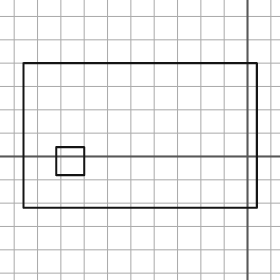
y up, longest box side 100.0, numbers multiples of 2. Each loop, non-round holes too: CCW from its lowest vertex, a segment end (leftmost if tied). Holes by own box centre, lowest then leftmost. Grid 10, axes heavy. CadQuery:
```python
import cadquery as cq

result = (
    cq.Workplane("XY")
    .moveTo(-96.0, -22.0)
    .lineTo(4.0, -22.0)
    .lineTo(4.0, 40.0)
    .lineTo(-96.0, 40.0)
    .close()
    .moveTo(-82.0, -8.0)
    .lineTo(-70.0, -8.0)
    .lineTo(-70.0, 4.0)
    .lineTo(-82.0, 4.0)
    .close()
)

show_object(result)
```